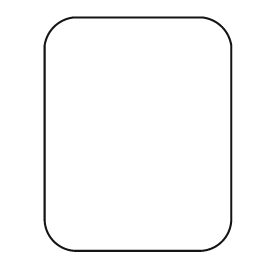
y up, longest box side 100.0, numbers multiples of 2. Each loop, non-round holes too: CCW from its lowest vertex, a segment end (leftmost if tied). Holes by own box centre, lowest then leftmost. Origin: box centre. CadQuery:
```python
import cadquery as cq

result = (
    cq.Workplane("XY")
    .moveTo(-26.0, -50.0)
    .lineTo(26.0, -50.0)
    .threePointArc((36.0, -46.0), (40.0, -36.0))
    .lineTo(40.0, 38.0)
    .threePointArc((36.0, 46.0), (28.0, 50.0))
    .lineTo(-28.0, 50.0)
    .threePointArc((-36.0, 46.0), (-40.0, 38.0))
    .lineTo(-40.0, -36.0)
    .threePointArc((-36.0, -46.0), (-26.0, -50.0))
    .close()
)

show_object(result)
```